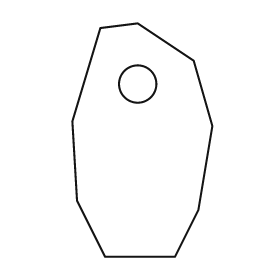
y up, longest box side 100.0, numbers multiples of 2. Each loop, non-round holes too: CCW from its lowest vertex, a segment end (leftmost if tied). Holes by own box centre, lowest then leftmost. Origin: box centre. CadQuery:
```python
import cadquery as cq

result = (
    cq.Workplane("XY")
    .moveTo(-16.0, -50.0)
    .lineTo(14.0, -50.0)
    .lineTo(24.0, -30.0)
    .lineTo(30.0, 6.0)
    .lineTo(22.0, 34.0)
    .lineTo(-2.0, 50.0)
    .lineTo(-18.0, 48.0)
    .lineTo(-30.0, 8.0)
    .lineTo(-28.0, -26.0)
    .close()
    .moveTo(-2.0, 24.0)
    .circle(8.0)
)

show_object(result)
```